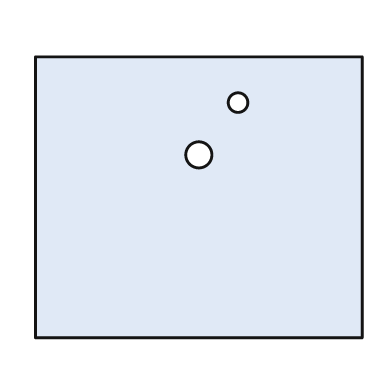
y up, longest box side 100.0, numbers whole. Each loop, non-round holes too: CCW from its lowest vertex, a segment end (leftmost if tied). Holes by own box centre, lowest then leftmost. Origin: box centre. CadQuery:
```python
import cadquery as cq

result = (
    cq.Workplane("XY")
    .moveTo(-50.0, -43.0)
    .lineTo(50.0, -43.0)
    .lineTo(50.0, 43.0)
    .lineTo(-50.0, 43.0)
    .close()
    .moveTo(0.0, 13.0)
    .circle(4.0)
    .moveTo(12.0, 29.0)
    .circle(3.0)
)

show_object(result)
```